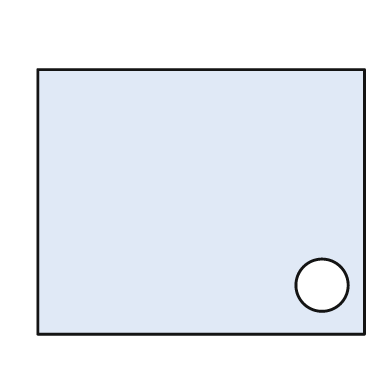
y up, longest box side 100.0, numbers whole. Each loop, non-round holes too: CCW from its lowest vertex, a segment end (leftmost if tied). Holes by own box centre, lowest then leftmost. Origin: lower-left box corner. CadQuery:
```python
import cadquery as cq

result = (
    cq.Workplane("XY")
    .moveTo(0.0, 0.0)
    .lineTo(100.0, 0.0)
    .lineTo(100.0, 81.0)
    .lineTo(0.0, 81.0)
    .close()
    .moveTo(87.0, 15.0)
    .circle(8.0)
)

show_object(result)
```